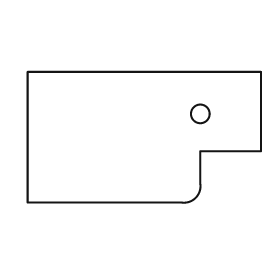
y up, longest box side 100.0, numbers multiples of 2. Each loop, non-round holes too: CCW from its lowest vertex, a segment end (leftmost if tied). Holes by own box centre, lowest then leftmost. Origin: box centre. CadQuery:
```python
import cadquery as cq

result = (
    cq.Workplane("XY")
    .moveTo(-50.0, -28.0)
    .lineTo(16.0, -28.0)
    .threePointArc((22.0, -26.0), (24.0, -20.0))
    .lineTo(24.0, -6.0)
    .lineTo(50.0, -6.0)
    .lineTo(50.0, 28.0)
    .lineTo(-50.0, 28.0)
    .close()
    .moveTo(24.0, 10.0)
    .circle(4.0)
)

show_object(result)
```